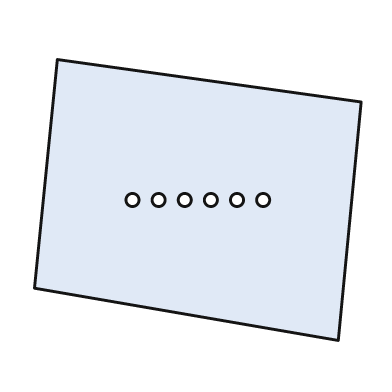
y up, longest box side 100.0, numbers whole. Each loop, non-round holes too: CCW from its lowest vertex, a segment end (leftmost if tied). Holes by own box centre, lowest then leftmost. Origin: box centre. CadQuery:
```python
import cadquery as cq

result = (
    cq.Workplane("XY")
    .moveTo(43.0, -43.0)
    .lineTo(50.0, 30.0)
    .lineTo(-43.0, 43.0)
    .lineTo(-50.0, -27.0)
    .close()
    .moveTo(-20.0, 0.0)
    .circle(2.0)
    .moveTo(-12.0, 0.0)
    .circle(2.0)
    .moveTo(-4.0, 0.0)
    .circle(2.0)
    .moveTo(4.0, 0.0)
    .circle(2.0)
    .moveTo(12.0, 0.0)
    .circle(2.0)
    .moveTo(20.0, 0.0)
    .circle(2.0)
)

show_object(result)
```